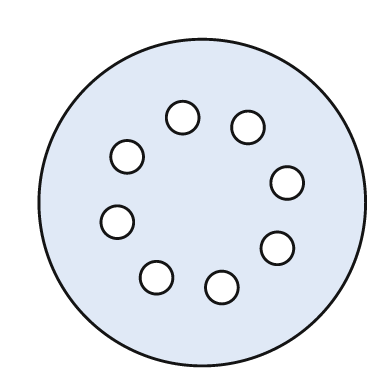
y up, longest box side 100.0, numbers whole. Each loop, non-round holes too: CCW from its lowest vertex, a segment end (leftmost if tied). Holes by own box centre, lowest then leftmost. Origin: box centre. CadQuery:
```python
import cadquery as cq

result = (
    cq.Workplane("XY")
    .moveTo(0.0, 0.0)
    .circle(50.0)
    .moveTo(6.0, -26.0)
    .circle(5.0)
    .moveTo(-14.0, -23.0)
    .circle(5.0)
    .moveTo(23.0, -14.0)
    .circle(5.0)
    .moveTo(-26.0, -6.0)
    .circle(5.0)
    .moveTo(26.0, 6.0)
    .circle(5.0)
    .moveTo(-23.0, 14.0)
    .circle(5.0)
    .moveTo(14.0, 23.0)
    .circle(5.0)
    .moveTo(-6.0, 26.0)
    .circle(5.0)
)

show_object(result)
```